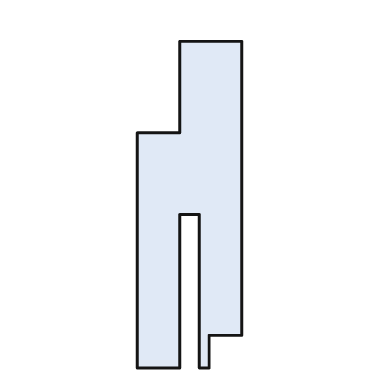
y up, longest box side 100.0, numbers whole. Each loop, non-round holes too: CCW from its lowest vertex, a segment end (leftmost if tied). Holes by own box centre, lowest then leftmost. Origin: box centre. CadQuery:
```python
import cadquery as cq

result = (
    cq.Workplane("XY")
    .moveTo(-16.0, -50.0)
    .lineTo(-3.0, -50.0)
    .lineTo(-3.0, -3.0)
    .lineTo(3.0, -3.0)
    .lineTo(3.0, -50.0)
    .lineTo(6.0, -50.0)
    .lineTo(6.0, -40.0)
    .lineTo(16.0, -40.0)
    .lineTo(16.0, 50.0)
    .lineTo(-3.0, 50.0)
    .lineTo(-3.0, 22.0)
    .lineTo(-16.0, 22.0)
    .close()
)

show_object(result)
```